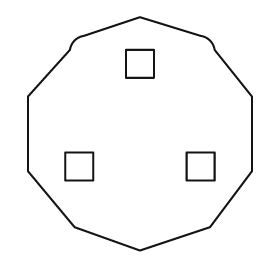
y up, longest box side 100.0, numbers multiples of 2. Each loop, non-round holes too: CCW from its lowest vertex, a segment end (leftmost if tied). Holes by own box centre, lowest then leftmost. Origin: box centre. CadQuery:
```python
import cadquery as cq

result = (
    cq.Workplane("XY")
    .moveTo(0.0, -50.0)
    .lineTo(30.0, -40.0)
    .lineTo(48.0, -16.0)
    .lineTo(48.0, 16.0)
    .lineTo(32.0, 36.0)
    .threePointArc((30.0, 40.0), (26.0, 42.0))
    .lineTo(0.0, 50.0)
    .lineTo(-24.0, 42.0)
    .threePointArc((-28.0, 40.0), (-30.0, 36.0))
    .lineTo(-48.0, 16.0)
    .lineTo(-48.0, -16.0)
    .lineTo(-28.0, -40.0)
    .close()
    .moveTo(-32.0, -20.0)
    .lineTo(-20.0, -20.0)
    .lineTo(-20.0, -8.0)
    .lineTo(-32.0, -8.0)
    .close()
    .moveTo(20.0, -20.0)
    .lineTo(32.0, -20.0)
    .lineTo(32.0, -8.0)
    .lineTo(20.0, -8.0)
    .close()
    .moveTo(-6.0, 24.0)
    .lineTo(6.0, 24.0)
    .lineTo(6.0, 36.0)
    .lineTo(-6.0, 36.0)
    .close()
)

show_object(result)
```